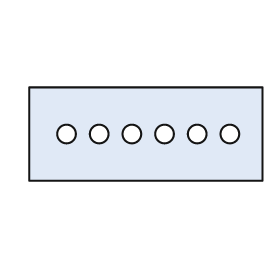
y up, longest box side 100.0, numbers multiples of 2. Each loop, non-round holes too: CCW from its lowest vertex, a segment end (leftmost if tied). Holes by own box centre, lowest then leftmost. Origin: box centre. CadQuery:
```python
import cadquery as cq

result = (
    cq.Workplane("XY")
    .moveTo(-50.0, -20.0)
    .lineTo(50.0, -20.0)
    .lineTo(50.0, 20.0)
    .lineTo(-50.0, 20.0)
    .close()
    .moveTo(-34.0, 0.0)
    .circle(4.0)
    .moveTo(-20.0, 0.0)
    .circle(4.0)
    .moveTo(-6.0, 0.0)
    .circle(4.0)
    .moveTo(8.0, 0.0)
    .circle(4.0)
    .moveTo(22.0, 0.0)
    .circle(4.0)
    .moveTo(36.0, 0.0)
    .circle(4.0)
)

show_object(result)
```